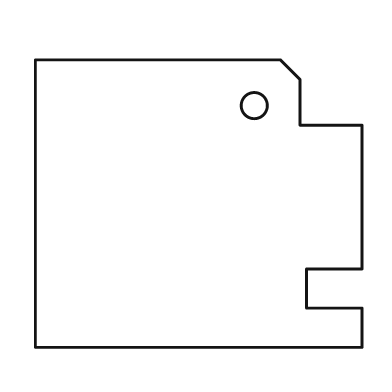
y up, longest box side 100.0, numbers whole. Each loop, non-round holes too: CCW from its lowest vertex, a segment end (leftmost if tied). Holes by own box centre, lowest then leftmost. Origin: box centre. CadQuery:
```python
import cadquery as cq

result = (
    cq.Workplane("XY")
    .moveTo(-50.0, -44.0)
    .lineTo(50.0, -44.0)
    .lineTo(50.0, -32.0)
    .lineTo(33.0, -32.0)
    .lineTo(33.0, -20.0)
    .lineTo(50.0, -20.0)
    .lineTo(50.0, 24.0)
    .lineTo(31.0, 24.0)
    .lineTo(31.0, 38.0)
    .lineTo(25.0, 44.0)
    .lineTo(-50.0, 44.0)
    .close()
    .moveTo(17.0, 30.0)
    .circle(4.0)
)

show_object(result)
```